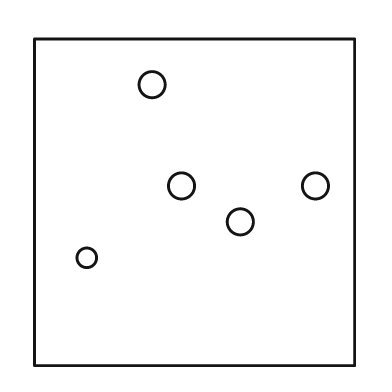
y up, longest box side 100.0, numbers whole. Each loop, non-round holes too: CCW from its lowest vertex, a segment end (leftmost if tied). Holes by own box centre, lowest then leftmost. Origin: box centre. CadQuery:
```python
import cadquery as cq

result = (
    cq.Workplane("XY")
    .moveTo(-49.0, -50.0)
    .lineTo(49.0, -50.0)
    .lineTo(49.0, 50.0)
    .lineTo(-49.0, 50.0)
    .close()
    .moveTo(-33.0, -17.0)
    .circle(3.0)
    .moveTo(14.0, -6.0)
    .circle(4.0)
    .moveTo(-4.0, 5.0)
    .circle(4.0)
    .moveTo(37.0, 5.0)
    .circle(4.0)
    .moveTo(-13.0, 36.0)
    .circle(4.0)
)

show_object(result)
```